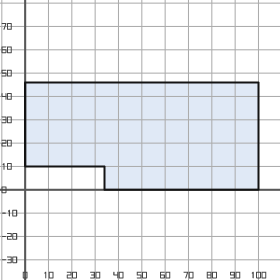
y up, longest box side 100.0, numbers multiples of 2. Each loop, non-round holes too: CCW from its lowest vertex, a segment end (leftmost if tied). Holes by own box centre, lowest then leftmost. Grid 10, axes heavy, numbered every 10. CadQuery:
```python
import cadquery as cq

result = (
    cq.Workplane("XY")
    .moveTo(34.0, 0.0)
    .lineTo(100.0, 0.0)
    .lineTo(100.0, 46.0)
    .lineTo(0.0, 46.0)
    .lineTo(0.0, 10.0)
    .lineTo(34.0, 10.0)
    .close()
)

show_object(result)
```